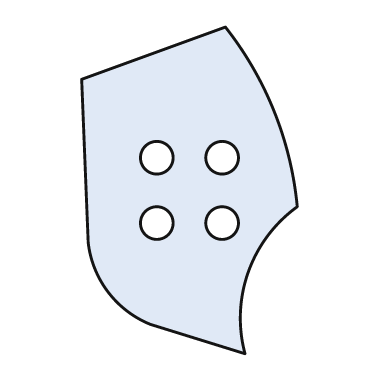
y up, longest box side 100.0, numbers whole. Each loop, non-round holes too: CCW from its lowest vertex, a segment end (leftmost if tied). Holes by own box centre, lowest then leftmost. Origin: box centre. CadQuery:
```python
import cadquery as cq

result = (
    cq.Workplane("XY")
    .moveTo(17.0, -50.0)
    .threePointArc((18.0, -25.0), (33.0, -5.0))
    .threePointArc((26.0, 24.0), (11.0, 50.0))
    .lineTo(-33.0, 34.0)
    .lineTo(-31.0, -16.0)
    .threePointArc((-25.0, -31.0), (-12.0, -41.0))
    .close()
    .moveTo(-10.0, -10.0)
    .circle(5.0)
    .moveTo(10.0, -10.0)
    .circle(5.0)
    .moveTo(-10.0, 10.0)
    .circle(5.0)
    .moveTo(10.0, 10.0)
    .circle(5.0)
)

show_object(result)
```